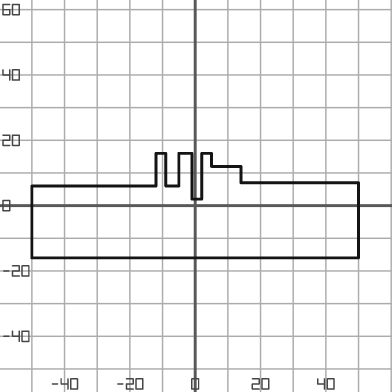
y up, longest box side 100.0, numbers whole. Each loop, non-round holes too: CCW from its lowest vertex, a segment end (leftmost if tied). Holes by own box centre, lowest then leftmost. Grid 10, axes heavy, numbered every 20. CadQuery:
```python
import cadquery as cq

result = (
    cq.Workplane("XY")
    .moveTo(-50.0, -16.0)
    .lineTo(50.0, -16.0)
    .lineTo(50.0, 7.0)
    .lineTo(14.0, 7.0)
    .lineTo(14.0, 12.0)
    .lineTo(5.0, 12.0)
    .lineTo(5.0, 16.0)
    .lineTo(2.0, 16.0)
    .lineTo(2.0, 2.0)
    .lineTo(-1.0, 2.0)
    .lineTo(-1.0, 16.0)
    .lineTo(-5.0, 16.0)
    .lineTo(-5.0, 6.0)
    .lineTo(-9.0, 6.0)
    .lineTo(-9.0, 16.0)
    .lineTo(-12.0, 16.0)
    .lineTo(-12.0, 6.0)
    .lineTo(-50.0, 6.0)
    .close()
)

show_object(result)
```